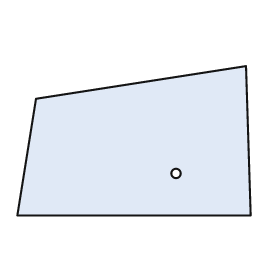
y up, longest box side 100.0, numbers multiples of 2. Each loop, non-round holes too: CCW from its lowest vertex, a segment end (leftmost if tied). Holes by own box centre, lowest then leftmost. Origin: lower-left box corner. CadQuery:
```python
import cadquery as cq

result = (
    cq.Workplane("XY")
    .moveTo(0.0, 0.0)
    .lineTo(100.0, 0.0)
    .lineTo(98.0, 64.0)
    .lineTo(8.0, 50.0)
    .close()
    .moveTo(68.0, 18.0)
    .circle(2.0)
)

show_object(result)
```